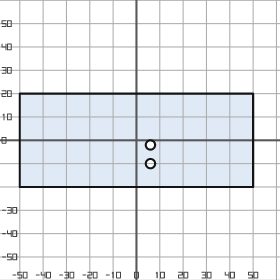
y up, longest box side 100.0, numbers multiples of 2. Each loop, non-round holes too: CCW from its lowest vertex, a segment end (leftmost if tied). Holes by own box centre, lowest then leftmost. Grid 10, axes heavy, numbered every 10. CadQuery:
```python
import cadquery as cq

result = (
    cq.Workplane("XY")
    .moveTo(-50.0, -20.0)
    .lineTo(50.0, -20.0)
    .lineTo(50.0, 20.0)
    .lineTo(-50.0, 20.0)
    .close()
    .moveTo(6.0, -10.0)
    .circle(2.0)
    .moveTo(6.0, -2.0)
    .circle(2.0)
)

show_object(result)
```